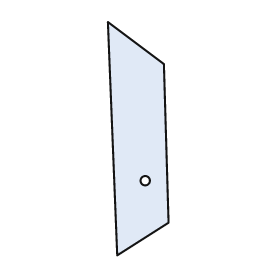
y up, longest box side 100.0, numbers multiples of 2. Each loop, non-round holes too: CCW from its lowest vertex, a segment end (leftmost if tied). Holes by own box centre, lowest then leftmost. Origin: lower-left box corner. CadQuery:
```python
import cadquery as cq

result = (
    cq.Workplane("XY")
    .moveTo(4.0, 0.0)
    .lineTo(26.0, 14.0)
    .lineTo(24.0, 82.0)
    .lineTo(0.0, 100.0)
    .close()
    .moveTo(16.0, 32.0)
    .circle(2.0)
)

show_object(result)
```